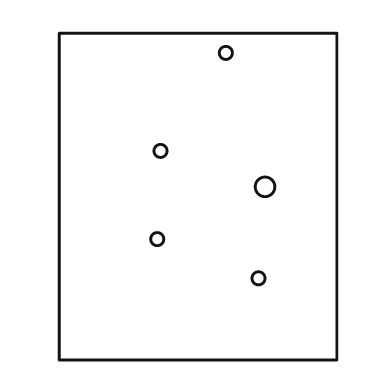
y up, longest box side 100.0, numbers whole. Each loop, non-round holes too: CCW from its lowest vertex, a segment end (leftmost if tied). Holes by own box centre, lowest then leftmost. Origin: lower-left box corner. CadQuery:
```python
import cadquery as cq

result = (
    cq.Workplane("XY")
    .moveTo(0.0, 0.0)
    .lineTo(85.0, 0.0)
    .lineTo(85.0, 100.0)
    .lineTo(0.0, 100.0)
    .close()
    .moveTo(61.0, 25.0)
    .circle(2.0)
    .moveTo(30.0, 37.0)
    .circle(2.0)
    .moveTo(63.0, 53.0)
    .circle(3.0)
    .moveTo(31.0, 64.0)
    .circle(2.0)
    .moveTo(51.0, 94.0)
    .circle(2.0)
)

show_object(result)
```